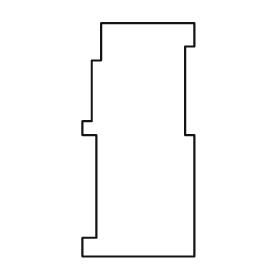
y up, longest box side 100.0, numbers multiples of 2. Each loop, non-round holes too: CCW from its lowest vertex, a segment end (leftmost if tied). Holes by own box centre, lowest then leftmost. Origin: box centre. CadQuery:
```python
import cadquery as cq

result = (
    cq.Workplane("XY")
    .moveTo(-24.0, -50.0)
    .lineTo(24.0, -50.0)
    .lineTo(24.0, 2.0)
    .lineTo(20.0, 2.0)
    .lineTo(20.0, 40.0)
    .lineTo(24.0, 40.0)
    .lineTo(24.0, 50.0)
    .lineTo(-16.0, 50.0)
    .lineTo(-16.0, 34.0)
    .lineTo(-20.0, 34.0)
    .lineTo(-20.0, 8.0)
    .lineTo(-24.0, 8.0)
    .lineTo(-24.0, 2.0)
    .lineTo(-18.0, 2.0)
    .lineTo(-18.0, -42.0)
    .lineTo(-24.0, -42.0)
    .close()
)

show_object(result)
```